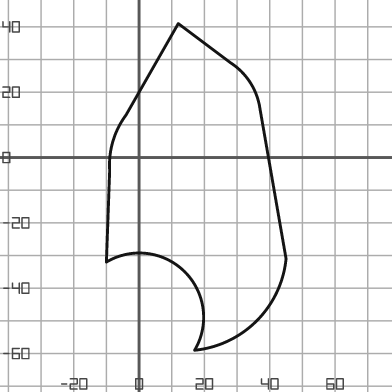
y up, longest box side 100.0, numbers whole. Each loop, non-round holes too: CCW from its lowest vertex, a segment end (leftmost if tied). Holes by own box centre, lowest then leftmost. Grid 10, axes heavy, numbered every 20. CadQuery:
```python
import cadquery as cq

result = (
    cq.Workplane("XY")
    .moveTo(17.0, -59.0)
    .threePointArc((36.0, -50.0), (45.0, -31.0))
    .lineTo(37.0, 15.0)
    .threePointArc((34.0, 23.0), (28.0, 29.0))
    .lineTo(12.0, 41.0)
    .lineTo(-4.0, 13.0)
    .threePointArc((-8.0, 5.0), (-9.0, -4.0))
    .lineTo(-10.0, -32.0)
    .threePointArc((14.0, -35.0), (17.0, -59.0))
    .close()
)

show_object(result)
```